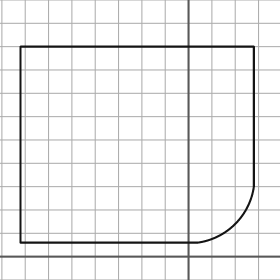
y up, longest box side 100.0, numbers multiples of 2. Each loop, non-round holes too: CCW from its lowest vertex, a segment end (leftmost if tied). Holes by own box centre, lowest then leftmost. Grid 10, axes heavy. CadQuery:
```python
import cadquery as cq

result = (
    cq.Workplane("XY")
    .moveTo(-72.0, 6.0)
    .lineTo(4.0, 6.0)
    .threePointArc((20.0, 14.0), (28.0, 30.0))
    .lineTo(28.0, 90.0)
    .lineTo(-72.0, 90.0)
    .close()
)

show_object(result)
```